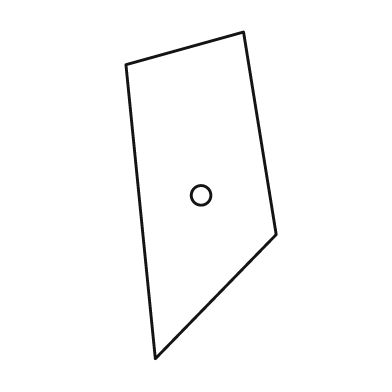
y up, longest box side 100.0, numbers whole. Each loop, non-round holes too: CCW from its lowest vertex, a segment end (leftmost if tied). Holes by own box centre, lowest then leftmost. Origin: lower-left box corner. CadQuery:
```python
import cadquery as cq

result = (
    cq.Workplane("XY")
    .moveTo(9.0, 0.0)
    .lineTo(46.0, 38.0)
    .lineTo(36.0, 100.0)
    .lineTo(0.0, 90.0)
    .close()
    .moveTo(23.0, 50.0)
    .circle(3.0)
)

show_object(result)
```